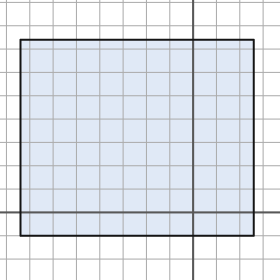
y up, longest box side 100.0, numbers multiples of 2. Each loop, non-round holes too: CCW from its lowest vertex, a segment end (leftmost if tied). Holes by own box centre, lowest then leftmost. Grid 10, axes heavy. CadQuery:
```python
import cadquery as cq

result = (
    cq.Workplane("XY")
    .moveTo(-74.0, -10.0)
    .lineTo(26.0, -10.0)
    .lineTo(26.0, 74.0)
    .lineTo(-74.0, 74.0)
    .close()
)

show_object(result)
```